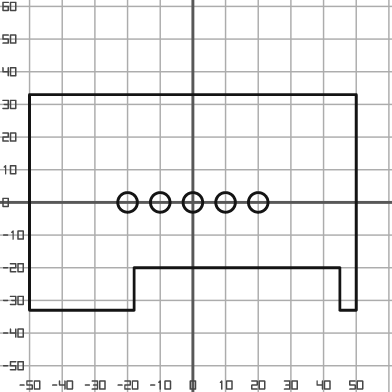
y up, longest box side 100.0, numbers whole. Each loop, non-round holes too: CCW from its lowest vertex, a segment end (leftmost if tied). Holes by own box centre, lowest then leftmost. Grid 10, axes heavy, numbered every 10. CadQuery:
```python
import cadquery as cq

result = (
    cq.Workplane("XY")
    .moveTo(-50.0, -33.0)
    .lineTo(-18.0, -33.0)
    .lineTo(-18.0, -20.0)
    .lineTo(45.0, -20.0)
    .lineTo(45.0, -33.0)
    .lineTo(50.0, -33.0)
    .lineTo(50.0, 33.0)
    .lineTo(-50.0, 33.0)
    .close()
    .moveTo(-20.0, 0.0)
    .circle(3.0)
    .moveTo(-10.0, 0.0)
    .circle(3.0)
    .moveTo(0.0, 0.0)
    .circle(3.0)
    .moveTo(10.0, 0.0)
    .circle(3.0)
    .moveTo(20.0, 0.0)
    .circle(3.0)
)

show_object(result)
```